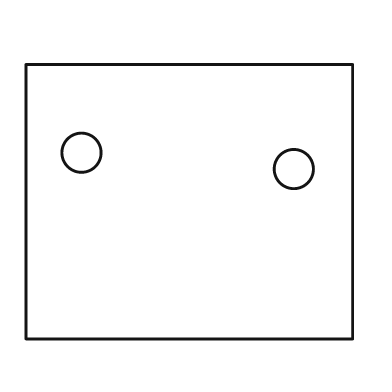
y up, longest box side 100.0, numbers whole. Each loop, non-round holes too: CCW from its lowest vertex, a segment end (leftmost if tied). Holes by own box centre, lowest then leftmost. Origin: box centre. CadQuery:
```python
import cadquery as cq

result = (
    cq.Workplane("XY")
    .moveTo(-50.0, -42.0)
    .lineTo(50.0, -42.0)
    .lineTo(50.0, 42.0)
    .lineTo(-50.0, 42.0)
    .close()
    .moveTo(32.0, 10.0)
    .circle(6.0)
    .moveTo(-33.0, 15.0)
    .circle(6.0)
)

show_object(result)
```